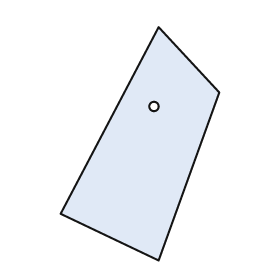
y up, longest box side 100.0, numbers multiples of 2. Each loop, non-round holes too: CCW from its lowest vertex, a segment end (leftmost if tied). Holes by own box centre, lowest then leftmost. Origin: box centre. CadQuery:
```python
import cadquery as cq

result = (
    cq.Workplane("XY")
    .moveTo(8.0, -50.0)
    .lineTo(34.0, 22.0)
    .lineTo(8.0, 50.0)
    .lineTo(-34.0, -30.0)
    .close()
    .moveTo(6.0, 16.0)
    .circle(2.0)
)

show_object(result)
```